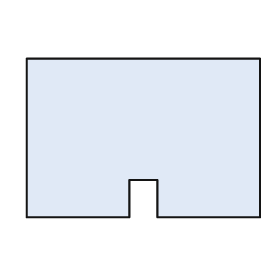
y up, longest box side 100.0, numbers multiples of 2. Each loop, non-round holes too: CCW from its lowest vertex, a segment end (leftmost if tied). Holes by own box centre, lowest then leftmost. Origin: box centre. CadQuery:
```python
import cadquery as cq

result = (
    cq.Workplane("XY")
    .moveTo(-50.0, -34.0)
    .lineTo(-6.0, -34.0)
    .lineTo(-6.0, -18.0)
    .lineTo(6.0, -18.0)
    .lineTo(6.0, -34.0)
    .lineTo(50.0, -34.0)
    .lineTo(50.0, 34.0)
    .lineTo(-50.0, 34.0)
    .close()
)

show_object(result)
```